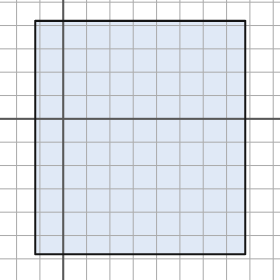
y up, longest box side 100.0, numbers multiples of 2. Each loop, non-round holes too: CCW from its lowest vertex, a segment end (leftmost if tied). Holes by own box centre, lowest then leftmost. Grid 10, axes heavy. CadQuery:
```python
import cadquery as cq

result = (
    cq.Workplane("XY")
    .moveTo(-12.0, -58.0)
    .lineTo(78.0, -58.0)
    .lineTo(78.0, 42.0)
    .lineTo(-12.0, 42.0)
    .close()
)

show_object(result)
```